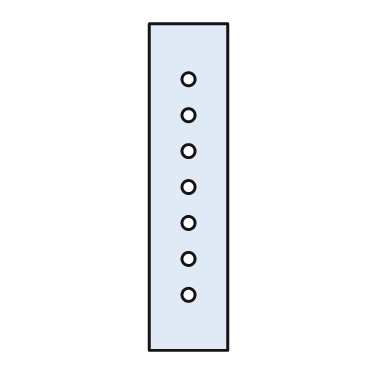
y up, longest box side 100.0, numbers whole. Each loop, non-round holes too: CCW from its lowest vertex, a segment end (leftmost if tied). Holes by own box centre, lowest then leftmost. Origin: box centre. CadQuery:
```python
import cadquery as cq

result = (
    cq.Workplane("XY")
    .moveTo(-12.0, -50.0)
    .lineTo(12.0, -50.0)
    .lineTo(12.0, 50.0)
    .lineTo(-12.0, 50.0)
    .close()
    .moveTo(0.0, -33.0)
    .circle(2.0)
    .moveTo(0.0, -22.0)
    .circle(2.0)
    .moveTo(0.0, -11.0)
    .circle(2.0)
    .moveTo(0.0, 0.0)
    .circle(2.0)
    .moveTo(0.0, 11.0)
    .circle(2.0)
    .moveTo(0.0, 22.0)
    .circle(2.0)
    .moveTo(0.0, 33.0)
    .circle(2.0)
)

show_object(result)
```